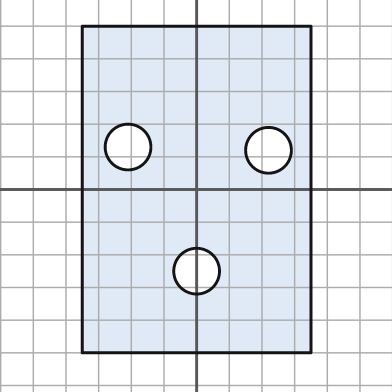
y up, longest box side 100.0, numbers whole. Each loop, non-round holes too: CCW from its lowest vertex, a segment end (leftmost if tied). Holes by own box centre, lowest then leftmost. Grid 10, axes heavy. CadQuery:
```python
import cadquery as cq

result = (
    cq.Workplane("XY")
    .moveTo(-35.0, -50.0)
    .lineTo(35.0, -50.0)
    .lineTo(35.0, 50.0)
    .lineTo(-35.0, 50.0)
    .close()
    .moveTo(0.0, -25.0)
    .circle(7.0)
    .moveTo(22.0, 12.0)
    .circle(7.0)
    .moveTo(-21.0, 13.0)
    .circle(7.0)
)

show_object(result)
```